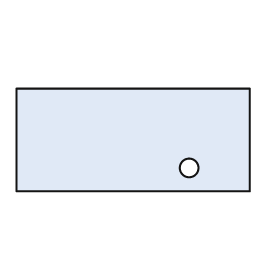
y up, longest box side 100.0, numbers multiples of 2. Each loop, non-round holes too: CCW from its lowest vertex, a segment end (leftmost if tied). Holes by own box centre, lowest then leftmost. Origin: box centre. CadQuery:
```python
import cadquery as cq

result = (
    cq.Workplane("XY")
    .moveTo(-50.0, -22.0)
    .lineTo(50.0, -22.0)
    .lineTo(50.0, 22.0)
    .lineTo(-50.0, 22.0)
    .close()
    .moveTo(24.0, -12.0)
    .circle(4.0)
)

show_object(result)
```